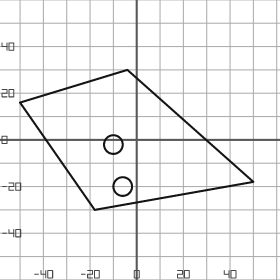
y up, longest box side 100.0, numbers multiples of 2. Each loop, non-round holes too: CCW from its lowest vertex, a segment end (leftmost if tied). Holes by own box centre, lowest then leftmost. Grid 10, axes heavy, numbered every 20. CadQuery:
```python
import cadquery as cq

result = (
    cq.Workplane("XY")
    .moveTo(-18.0, -30.0)
    .lineTo(50.0, -18.0)
    .lineTo(-4.0, 30.0)
    .lineTo(-50.0, 16.0)
    .close()
    .moveTo(-6.0, -20.0)
    .circle(4.0)
    .moveTo(-10.0, -2.0)
    .circle(4.0)
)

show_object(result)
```